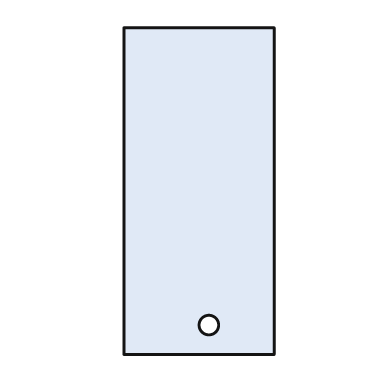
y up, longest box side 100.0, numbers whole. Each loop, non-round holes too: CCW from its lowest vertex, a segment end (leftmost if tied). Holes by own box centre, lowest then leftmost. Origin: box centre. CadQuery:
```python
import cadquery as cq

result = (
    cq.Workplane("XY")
    .moveTo(-23.0, -50.0)
    .lineTo(23.0, -50.0)
    .lineTo(23.0, 50.0)
    .lineTo(-23.0, 50.0)
    .close()
    .moveTo(3.0, -41.0)
    .circle(3.0)
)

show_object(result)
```